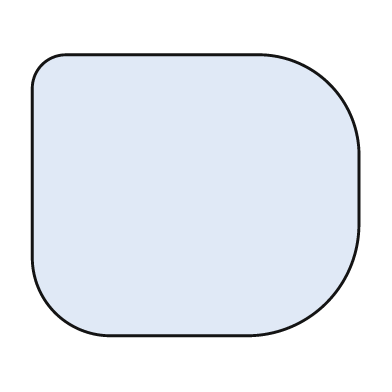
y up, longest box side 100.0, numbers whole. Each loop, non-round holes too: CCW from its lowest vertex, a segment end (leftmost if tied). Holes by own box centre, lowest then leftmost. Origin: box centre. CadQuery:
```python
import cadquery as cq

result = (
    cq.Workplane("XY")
    .moveTo(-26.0, -43.0)
    .lineTo(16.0, -43.0)
    .threePointArc((40.0, -33.0), (50.0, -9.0))
    .lineTo(50.0, 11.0)
    .threePointArc((41.0, 34.0), (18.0, 43.0))
    .lineTo(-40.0, 43.0)
    .threePointArc((-47.0, 40.0), (-50.0, 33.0))
    .lineTo(-50.0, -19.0)
    .threePointArc((-43.0, -36.0), (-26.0, -43.0))
    .close()
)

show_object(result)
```